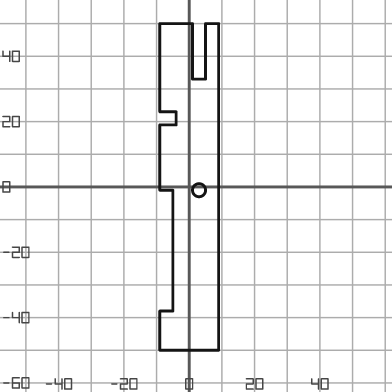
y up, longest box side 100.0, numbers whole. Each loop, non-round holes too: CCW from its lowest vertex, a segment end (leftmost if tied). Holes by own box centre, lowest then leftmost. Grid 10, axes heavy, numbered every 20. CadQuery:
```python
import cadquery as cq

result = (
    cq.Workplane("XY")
    .moveTo(-9.0, -50.0)
    .lineTo(9.0, -50.0)
    .lineTo(9.0, 50.0)
    .lineTo(5.0, 50.0)
    .lineTo(5.0, 33.0)
    .lineTo(1.0, 33.0)
    .lineTo(1.0, 50.0)
    .lineTo(-9.0, 50.0)
    .lineTo(-9.0, 23.0)
    .lineTo(-4.0, 23.0)
    .lineTo(-4.0, 19.0)
    .lineTo(-9.0, 19.0)
    .lineTo(-9.0, -1.0)
    .lineTo(-5.0, -1.0)
    .lineTo(-5.0, -38.0)
    .lineTo(-9.0, -38.0)
    .close()
    .moveTo(3.0, -1.0)
    .circle(2.0)
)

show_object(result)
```